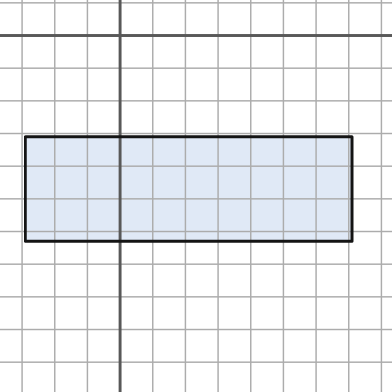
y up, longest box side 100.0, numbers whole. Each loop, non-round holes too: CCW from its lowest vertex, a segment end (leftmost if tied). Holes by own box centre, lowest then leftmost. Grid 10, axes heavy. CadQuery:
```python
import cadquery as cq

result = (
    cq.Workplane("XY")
    .moveTo(-29.0, -63.0)
    .lineTo(71.0, -63.0)
    .lineTo(71.0, -31.0)
    .lineTo(-29.0, -31.0)
    .close()
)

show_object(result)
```